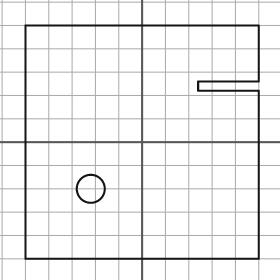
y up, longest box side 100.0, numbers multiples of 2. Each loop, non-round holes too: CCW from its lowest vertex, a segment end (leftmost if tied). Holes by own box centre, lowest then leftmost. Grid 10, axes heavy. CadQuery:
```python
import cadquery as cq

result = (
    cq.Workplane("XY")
    .moveTo(-50.0, -50.0)
    .lineTo(50.0, -50.0)
    .lineTo(50.0, 22.0)
    .lineTo(24.0, 22.0)
    .lineTo(24.0, 26.0)
    .lineTo(50.0, 26.0)
    .lineTo(50.0, 50.0)
    .lineTo(-50.0, 50.0)
    .close()
    .moveTo(-22.0, -20.0)
    .circle(6.0)
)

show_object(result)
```